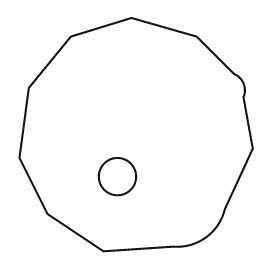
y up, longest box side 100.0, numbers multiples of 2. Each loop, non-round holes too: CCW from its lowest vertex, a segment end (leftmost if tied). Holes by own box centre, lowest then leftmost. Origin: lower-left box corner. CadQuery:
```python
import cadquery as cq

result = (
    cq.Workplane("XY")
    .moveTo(36.0, 0.0)
    .lineTo(66.0, 2.0)
    .threePointArc((80.0, 6.0), (88.0, 18.0))
    .lineTo(100.0, 44.0)
    .lineTo(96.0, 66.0)
    .threePointArc((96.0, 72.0), (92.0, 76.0))
    .lineTo(76.0, 92.0)
    .lineTo(48.0, 100.0)
    .lineTo(22.0, 92.0)
    .lineTo(4.0, 70.0)
    .lineTo(0.0, 40.0)
    .lineTo(12.0, 16.0)
    .close()
    .moveTo(42.0, 32.0)
    .circle(8.0)
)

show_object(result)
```